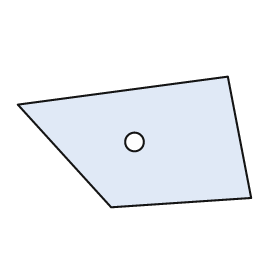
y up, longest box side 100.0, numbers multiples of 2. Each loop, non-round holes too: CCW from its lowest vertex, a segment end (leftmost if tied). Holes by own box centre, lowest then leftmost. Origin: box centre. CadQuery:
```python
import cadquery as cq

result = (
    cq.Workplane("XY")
    .moveTo(-10.0, -28.0)
    .lineTo(50.0, -24.0)
    .lineTo(40.0, 28.0)
    .lineTo(-50.0, 16.0)
    .close()
    .moveTo(0.0, 0.0)
    .circle(4.0)
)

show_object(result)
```